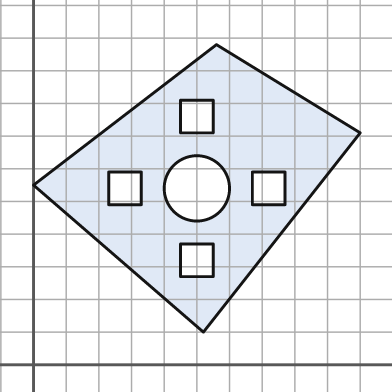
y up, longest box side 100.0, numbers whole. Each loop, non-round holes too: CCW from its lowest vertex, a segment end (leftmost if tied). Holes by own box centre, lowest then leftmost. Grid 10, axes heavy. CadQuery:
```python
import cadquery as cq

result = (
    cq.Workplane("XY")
    .moveTo(52.0, 10.0)
    .lineTo(100.0, 71.0)
    .lineTo(56.0, 98.0)
    .lineTo(0.0, 55.0)
    .close()
    .moveTo(45.0, 27.0)
    .lineTo(55.0, 27.0)
    .lineTo(55.0, 37.0)
    .lineTo(45.0, 37.0)
    .close()
    .moveTo(23.0, 49.0)
    .lineTo(33.0, 49.0)
    .lineTo(33.0, 59.0)
    .lineTo(23.0, 59.0)
    .close()
    .moveTo(50.0, 54.0)
    .circle(10.0)
    .moveTo(67.0, 49.0)
    .lineTo(77.0, 49.0)
    .lineTo(77.0, 59.0)
    .lineTo(67.0, 59.0)
    .close()
    .moveTo(45.0, 71.0)
    .lineTo(55.0, 71.0)
    .lineTo(55.0, 81.0)
    .lineTo(45.0, 81.0)
    .close()
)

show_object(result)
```